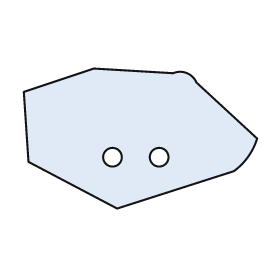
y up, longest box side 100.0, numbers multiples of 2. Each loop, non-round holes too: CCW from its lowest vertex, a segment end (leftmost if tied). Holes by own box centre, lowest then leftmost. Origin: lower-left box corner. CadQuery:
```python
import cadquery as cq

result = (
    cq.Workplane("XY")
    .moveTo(40.0, 0.0)
    .lineTo(90.0, 16.0)
    .threePointArc((96.0, 22.0), (100.0, 30.0))
    .lineTo(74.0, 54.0)
    .threePointArc((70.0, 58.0), (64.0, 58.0))
    .lineTo(30.0, 60.0)
    .lineTo(0.0, 50.0)
    .lineTo(2.0, 20.0)
    .close()
    .moveTo(38.0, 22.0)
    .circle(4.0)
    .moveTo(58.0, 22.0)
    .circle(4.0)
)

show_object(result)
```